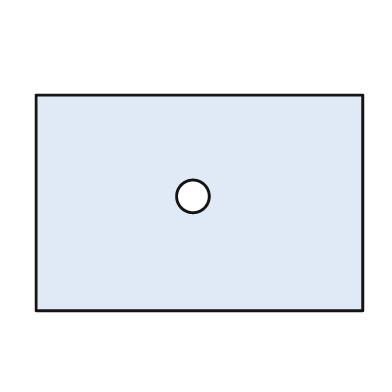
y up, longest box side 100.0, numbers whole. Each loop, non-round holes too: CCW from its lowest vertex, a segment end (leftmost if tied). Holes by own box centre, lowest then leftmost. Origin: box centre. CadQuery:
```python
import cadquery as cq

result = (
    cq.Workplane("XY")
    .moveTo(-50.0, -33.0)
    .lineTo(50.0, -33.0)
    .lineTo(50.0, 33.0)
    .lineTo(-50.0, 33.0)
    .close()
    .moveTo(-2.0, 2.0)
    .circle(5.0)
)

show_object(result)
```